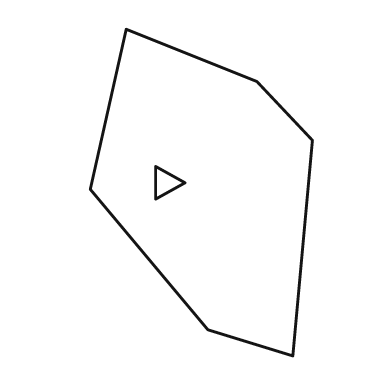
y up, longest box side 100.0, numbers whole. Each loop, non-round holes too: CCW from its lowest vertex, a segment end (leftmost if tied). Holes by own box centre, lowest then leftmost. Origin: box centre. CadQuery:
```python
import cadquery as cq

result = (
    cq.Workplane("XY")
    .moveTo(28.0, -50.0)
    .lineTo(34.0, 16.0)
    .lineTo(17.0, 34.0)
    .lineTo(-23.0, 50.0)
    .lineTo(-34.0, 1.0)
    .lineTo(2.0, -42.0)
    .close()
    .moveTo(-14.0, -2.0)
    .lineTo(-5.0, 3.0)
    .lineTo(-14.0, 8.0)
    .close()
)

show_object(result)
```